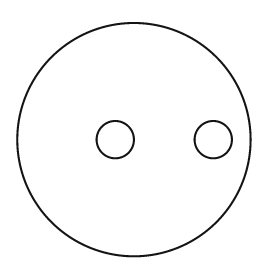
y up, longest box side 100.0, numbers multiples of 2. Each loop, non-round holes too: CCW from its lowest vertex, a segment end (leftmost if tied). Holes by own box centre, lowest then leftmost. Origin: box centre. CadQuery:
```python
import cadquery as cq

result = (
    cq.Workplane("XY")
    .moveTo(0.0, 0.0)
    .circle(50.0)
    .moveTo(-8.0, 0.0)
    .circle(8.0)
    .moveTo(34.0, 0.0)
    .circle(8.0)
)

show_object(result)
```